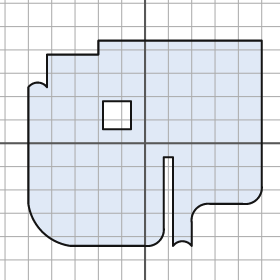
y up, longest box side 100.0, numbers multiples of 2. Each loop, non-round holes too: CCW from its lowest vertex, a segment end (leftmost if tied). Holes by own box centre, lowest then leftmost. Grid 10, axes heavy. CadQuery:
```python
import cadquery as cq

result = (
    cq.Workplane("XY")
    .moveTo(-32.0, -44.0)
    .lineTo(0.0, -44.0)
    .threePointArc((6.0, -42.0), (8.0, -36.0))
    .lineTo(8.0, -6.0)
    .lineTo(12.0, -6.0)
    .lineTo(12.0, -44.0)
    .threePointArc((16.0, -42.0), (20.0, -44.0))
    .lineTo(20.0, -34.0)
    .threePointArc((22.0, -28.0), (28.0, -26.0))
    .lineTo(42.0, -26.0)
    .threePointArc((48.0, -24.0), (50.0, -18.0))
    .lineTo(50.0, 44.0)
    .lineTo(-20.0, 44.0)
    .lineTo(-20.0, 38.0)
    .lineTo(-42.0, 38.0)
    .lineTo(-42.0, 24.0)
    .threePointArc((-46.0, 26.0), (-50.0, 24.0))
    .lineTo(-50.0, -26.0)
    .threePointArc((-44.0, -38.0), (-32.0, -44.0))
    .close()
    .moveTo(-18.0, 6.0)
    .lineTo(-6.0, 6.0)
    .lineTo(-6.0, 18.0)
    .lineTo(-18.0, 18.0)
    .close()
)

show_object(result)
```